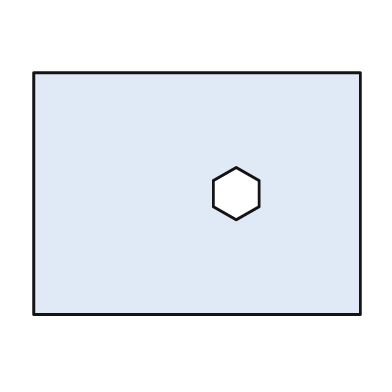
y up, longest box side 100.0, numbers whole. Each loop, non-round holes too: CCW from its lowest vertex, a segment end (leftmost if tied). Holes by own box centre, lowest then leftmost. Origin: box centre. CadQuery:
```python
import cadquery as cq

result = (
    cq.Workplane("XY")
    .moveTo(-50.0, -37.0)
    .lineTo(50.0, -37.0)
    .lineTo(50.0, 37.0)
    .lineTo(-50.0, 37.0)
    .close()
    .moveTo(12.0, -8.0)
    .lineTo(19.0, -4.0)
    .lineTo(19.0, 4.0)
    .lineTo(12.0, 8.0)
    .lineTo(5.0, 4.0)
    .lineTo(5.0, -4.0)
    .close()
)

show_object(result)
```